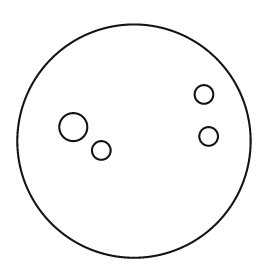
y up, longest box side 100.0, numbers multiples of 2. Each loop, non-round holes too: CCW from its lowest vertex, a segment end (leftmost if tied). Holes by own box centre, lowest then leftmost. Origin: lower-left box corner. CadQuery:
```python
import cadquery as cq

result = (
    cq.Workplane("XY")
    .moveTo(50.0, 50.0)
    .circle(50.0)
    .moveTo(36.0, 46.0)
    .circle(4.0)
    .moveTo(82.0, 52.0)
    .circle(4.0)
    .moveTo(24.0, 56.0)
    .circle(6.0)
    .moveTo(80.0, 70.0)
    .circle(4.0)
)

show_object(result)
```